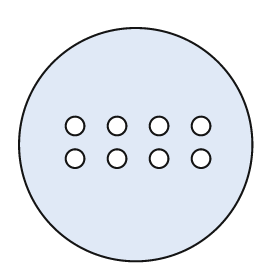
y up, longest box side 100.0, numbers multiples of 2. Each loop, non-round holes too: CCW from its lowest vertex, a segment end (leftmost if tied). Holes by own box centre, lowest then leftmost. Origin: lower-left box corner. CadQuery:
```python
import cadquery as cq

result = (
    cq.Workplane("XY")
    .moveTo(50.0, 50.0)
    .circle(50.0)
    .moveTo(24.0, 44.0)
    .circle(4.0)
    .moveTo(42.0, 44.0)
    .circle(4.0)
    .moveTo(60.0, 44.0)
    .circle(4.0)
    .moveTo(78.0, 44.0)
    .circle(4.0)
    .moveTo(24.0, 58.0)
    .circle(4.0)
    .moveTo(42.0, 58.0)
    .circle(4.0)
    .moveTo(60.0, 58.0)
    .circle(4.0)
    .moveTo(78.0, 58.0)
    .circle(4.0)
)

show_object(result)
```